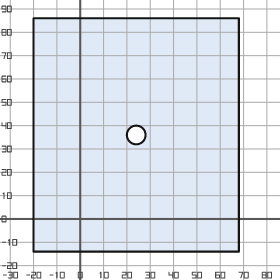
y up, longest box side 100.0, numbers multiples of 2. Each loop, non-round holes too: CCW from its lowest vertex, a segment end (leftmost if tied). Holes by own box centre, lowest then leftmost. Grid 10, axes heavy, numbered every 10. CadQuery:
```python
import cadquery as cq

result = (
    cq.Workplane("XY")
    .moveTo(-20.0, -14.0)
    .lineTo(68.0, -14.0)
    .lineTo(68.0, 86.0)
    .lineTo(-20.0, 86.0)
    .close()
    .moveTo(24.0, 36.0)
    .circle(4.0)
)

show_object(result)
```